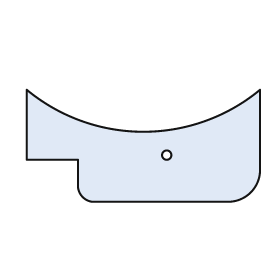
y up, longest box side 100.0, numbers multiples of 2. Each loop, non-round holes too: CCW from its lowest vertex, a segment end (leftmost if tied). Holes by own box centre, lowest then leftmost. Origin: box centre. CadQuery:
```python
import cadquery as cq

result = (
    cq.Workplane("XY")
    .moveTo(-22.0, -24.0)
    .lineTo(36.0, -24.0)
    .threePointArc((46.0, -20.0), (50.0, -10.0))
    .lineTo(50.0, 24.0)
    .threePointArc((0.0, 6.0), (-50.0, 24.0))
    .lineTo(-50.0, -6.0)
    .lineTo(-28.0, -6.0)
    .lineTo(-28.0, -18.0)
    .threePointArc((-26.0, -22.0), (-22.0, -24.0))
    .close()
    .moveTo(10.0, -4.0)
    .circle(2.0)
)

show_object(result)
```